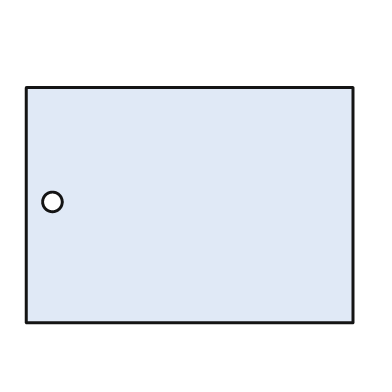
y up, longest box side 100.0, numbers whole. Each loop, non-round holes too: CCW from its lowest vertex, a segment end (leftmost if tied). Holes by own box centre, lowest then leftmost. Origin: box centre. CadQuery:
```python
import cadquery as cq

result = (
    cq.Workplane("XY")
    .moveTo(-50.0, -36.0)
    .lineTo(50.0, -36.0)
    .lineTo(50.0, 36.0)
    .lineTo(-50.0, 36.0)
    .close()
    .moveTo(-42.0, 1.0)
    .circle(3.0)
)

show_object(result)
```